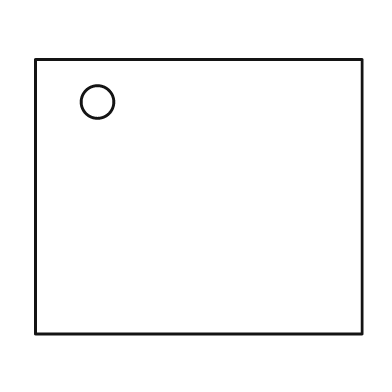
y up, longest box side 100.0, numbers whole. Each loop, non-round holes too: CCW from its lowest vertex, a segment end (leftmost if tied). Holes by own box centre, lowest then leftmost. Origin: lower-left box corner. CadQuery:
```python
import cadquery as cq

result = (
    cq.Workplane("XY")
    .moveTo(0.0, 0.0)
    .lineTo(100.0, 0.0)
    .lineTo(100.0, 84.0)
    .lineTo(0.0, 84.0)
    .close()
    .moveTo(19.0, 71.0)
    .circle(5.0)
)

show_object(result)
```